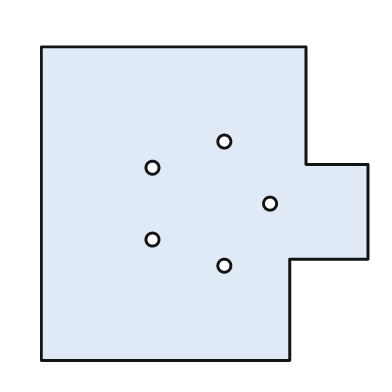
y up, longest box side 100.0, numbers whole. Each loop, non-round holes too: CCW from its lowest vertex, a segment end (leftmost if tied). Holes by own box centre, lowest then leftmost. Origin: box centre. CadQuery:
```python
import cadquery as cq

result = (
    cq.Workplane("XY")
    .moveTo(-50.0, -48.0)
    .lineTo(26.0, -48.0)
    .lineTo(26.0, -17.0)
    .lineTo(50.0, -17.0)
    .lineTo(50.0, 12.0)
    .lineTo(31.0, 12.0)
    .lineTo(31.0, 48.0)
    .lineTo(-50.0, 48.0)
    .close()
    .moveTo(6.0, -19.0)
    .circle(2.0)
    .moveTo(-16.0, -11.0)
    .circle(2.0)
    .moveTo(20.0, 0.0)
    .circle(2.0)
    .moveTo(-16.0, 11.0)
    .circle(2.0)
    .moveTo(6.0, 19.0)
    .circle(2.0)
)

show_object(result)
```